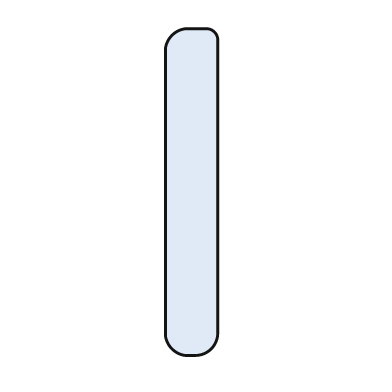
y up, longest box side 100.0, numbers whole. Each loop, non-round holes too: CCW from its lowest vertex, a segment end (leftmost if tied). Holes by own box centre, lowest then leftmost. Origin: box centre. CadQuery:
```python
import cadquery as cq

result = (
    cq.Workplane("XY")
    .moveTo(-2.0, -50.0)
    .lineTo(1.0, -50.0)
    .threePointArc((6.0, -48.0), (8.0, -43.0))
    .lineTo(8.0, 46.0)
    .threePointArc((7.0, 49.0), (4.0, 50.0))
    .lineTo(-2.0, 50.0)
    .threePointArc((-6.0, 48.0), (-8.0, 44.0))
    .lineTo(-8.0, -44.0)
    .threePointArc((-6.0, -48.0), (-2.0, -50.0))
    .close()
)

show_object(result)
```